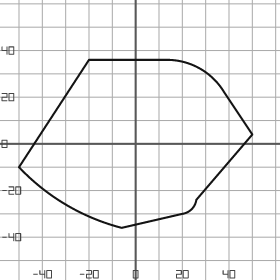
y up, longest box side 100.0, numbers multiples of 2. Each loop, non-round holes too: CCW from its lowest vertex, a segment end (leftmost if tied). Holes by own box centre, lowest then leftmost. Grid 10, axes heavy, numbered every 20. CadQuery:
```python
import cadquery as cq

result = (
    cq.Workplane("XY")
    .moveTo(-6.0, -36.0)
    .lineTo(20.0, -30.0)
    .threePointArc((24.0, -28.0), (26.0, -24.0))
    .lineTo(50.0, 4.0)
    .lineTo(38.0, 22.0)
    .threePointArc((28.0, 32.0), (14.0, 36.0))
    .lineTo(-20.0, 36.0)
    .lineTo(-50.0, -10.0)
    .threePointArc((-30.0, -26.0), (-6.0, -36.0))
    .close()
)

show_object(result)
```